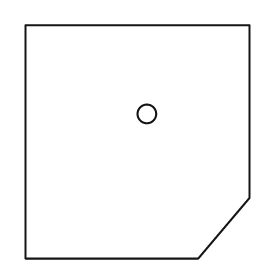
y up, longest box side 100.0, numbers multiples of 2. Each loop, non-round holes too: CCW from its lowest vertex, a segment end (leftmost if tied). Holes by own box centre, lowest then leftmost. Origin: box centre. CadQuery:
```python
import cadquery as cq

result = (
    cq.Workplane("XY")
    .moveTo(-48.0, -50.0)
    .lineTo(26.0, -50.0)
    .lineTo(48.0, -24.0)
    .lineTo(48.0, 50.0)
    .lineTo(-48.0, 50.0)
    .close()
    .moveTo(4.0, 12.0)
    .circle(4.0)
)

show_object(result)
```